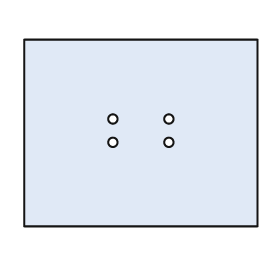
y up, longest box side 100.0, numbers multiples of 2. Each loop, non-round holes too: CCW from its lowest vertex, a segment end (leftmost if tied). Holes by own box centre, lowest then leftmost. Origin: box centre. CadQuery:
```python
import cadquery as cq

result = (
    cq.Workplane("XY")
    .moveTo(-50.0, -40.0)
    .lineTo(50.0, -40.0)
    .lineTo(50.0, 40.0)
    .lineTo(-50.0, 40.0)
    .close()
    .moveTo(-12.0, -4.0)
    .circle(2.0)
    .moveTo(12.0, -4.0)
    .circle(2.0)
    .moveTo(-12.0, 6.0)
    .circle(2.0)
    .moveTo(12.0, 6.0)
    .circle(2.0)
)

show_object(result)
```